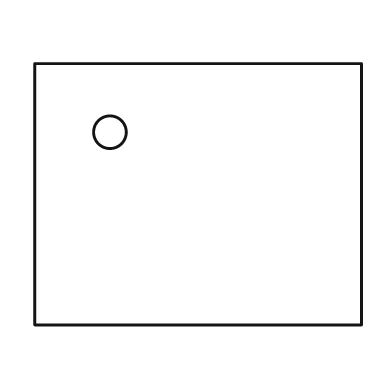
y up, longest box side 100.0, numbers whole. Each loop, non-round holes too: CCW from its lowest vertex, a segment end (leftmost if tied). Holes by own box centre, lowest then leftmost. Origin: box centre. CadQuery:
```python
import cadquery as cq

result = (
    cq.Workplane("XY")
    .moveTo(-50.0, -40.0)
    .lineTo(50.0, -40.0)
    .lineTo(50.0, 40.0)
    .lineTo(-50.0, 40.0)
    .close()
    .moveTo(-27.0, 19.0)
    .circle(5.0)
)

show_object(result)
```